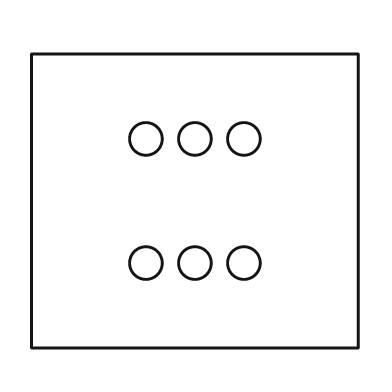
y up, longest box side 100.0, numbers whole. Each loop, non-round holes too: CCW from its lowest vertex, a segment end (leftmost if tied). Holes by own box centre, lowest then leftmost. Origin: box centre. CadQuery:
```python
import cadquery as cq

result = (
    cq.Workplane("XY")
    .moveTo(-50.0, -45.0)
    .lineTo(50.0, -45.0)
    .lineTo(50.0, 45.0)
    .lineTo(-50.0, 45.0)
    .close()
    .moveTo(-15.0, -19.0)
    .circle(5.0)
    .moveTo(0.0, -19.0)
    .circle(5.0)
    .moveTo(15.0, -19.0)
    .circle(5.0)
    .moveTo(-15.0, 19.0)
    .circle(5.0)
    .moveTo(0.0, 19.0)
    .circle(5.0)
    .moveTo(15.0, 19.0)
    .circle(5.0)
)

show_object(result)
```